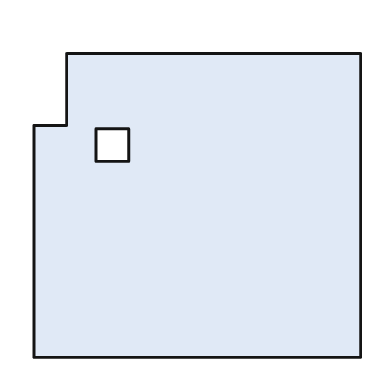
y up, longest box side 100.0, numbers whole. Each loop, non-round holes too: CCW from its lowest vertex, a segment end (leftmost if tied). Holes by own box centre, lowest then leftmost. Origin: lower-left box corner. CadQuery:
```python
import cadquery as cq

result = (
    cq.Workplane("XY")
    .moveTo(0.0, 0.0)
    .lineTo(100.0, 0.0)
    .lineTo(100.0, 93.0)
    .lineTo(10.0, 93.0)
    .lineTo(10.0, 71.0)
    .lineTo(0.0, 71.0)
    .close()
    .moveTo(19.0, 60.0)
    .lineTo(29.0, 60.0)
    .lineTo(29.0, 70.0)
    .lineTo(19.0, 70.0)
    .close()
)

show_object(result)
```